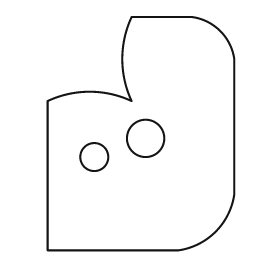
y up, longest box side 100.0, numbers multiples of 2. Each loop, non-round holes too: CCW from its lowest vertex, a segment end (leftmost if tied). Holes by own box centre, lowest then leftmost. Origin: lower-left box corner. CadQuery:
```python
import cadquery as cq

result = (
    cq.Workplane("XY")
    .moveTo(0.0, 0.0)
    .lineTo(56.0, 0.0)
    .threePointArc((72.0, 8.0), (80.0, 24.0))
    .lineTo(80.0, 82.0)
    .threePointArc((74.0, 94.0), (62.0, 100.0))
    .lineTo(36.0, 100.0)
    .threePointArc((32.0, 82.0), (36.0, 64.0))
    .threePointArc((18.0, 68.0), (0.0, 64.0))
    .close()
    .moveTo(20.0, 40.0)
    .circle(6.0)
    .moveTo(42.0, 48.0)
    .circle(8.0)
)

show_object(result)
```